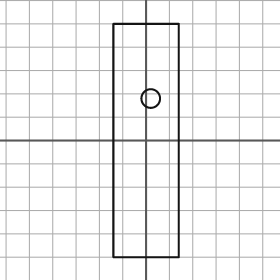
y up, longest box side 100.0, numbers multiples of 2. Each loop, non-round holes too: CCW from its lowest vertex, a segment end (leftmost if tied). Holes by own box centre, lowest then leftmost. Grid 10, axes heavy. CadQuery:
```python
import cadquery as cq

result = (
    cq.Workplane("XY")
    .moveTo(-14.0, -50.0)
    .lineTo(14.0, -50.0)
    .lineTo(14.0, 50.0)
    .lineTo(-14.0, 50.0)
    .close()
    .moveTo(2.0, 18.0)
    .circle(4.0)
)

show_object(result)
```